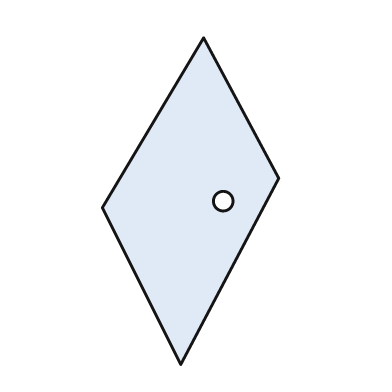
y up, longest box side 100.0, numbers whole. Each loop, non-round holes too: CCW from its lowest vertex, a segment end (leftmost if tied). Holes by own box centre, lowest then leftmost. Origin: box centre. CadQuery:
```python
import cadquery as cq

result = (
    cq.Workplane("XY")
    .moveTo(-3.0, -50.0)
    .lineTo(27.0, 7.0)
    .lineTo(4.0, 50.0)
    .lineTo(-27.0, -2.0)
    .close()
    .moveTo(10.0, 0.0)
    .circle(3.0)
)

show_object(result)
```